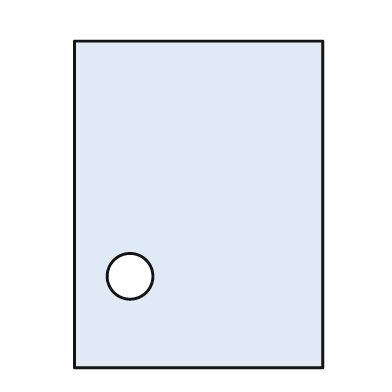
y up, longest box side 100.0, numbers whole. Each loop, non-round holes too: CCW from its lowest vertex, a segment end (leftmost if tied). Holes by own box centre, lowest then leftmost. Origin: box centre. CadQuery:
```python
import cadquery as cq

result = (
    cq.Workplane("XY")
    .moveTo(-38.0, -50.0)
    .lineTo(38.0, -50.0)
    .lineTo(38.0, 50.0)
    .lineTo(-38.0, 50.0)
    .close()
    .moveTo(-21.0, -22.0)
    .circle(7.0)
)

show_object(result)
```